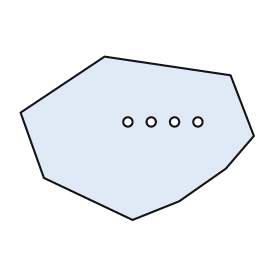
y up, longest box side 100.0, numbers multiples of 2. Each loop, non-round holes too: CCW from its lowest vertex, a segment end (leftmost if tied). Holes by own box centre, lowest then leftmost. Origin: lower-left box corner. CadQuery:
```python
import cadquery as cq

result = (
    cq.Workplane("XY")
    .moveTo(48.0, 0.0)
    .lineTo(68.0, 8.0)
    .lineTo(88.0, 22.0)
    .lineTo(100.0, 36.0)
    .lineTo(90.0, 62.0)
    .lineTo(36.0, 70.0)
    .lineTo(0.0, 46.0)
    .lineTo(10.0, 18.0)
    .close()
    .moveTo(46.0, 42.0)
    .circle(2.0)
    .moveTo(56.0, 42.0)
    .circle(2.0)
    .moveTo(66.0, 42.0)
    .circle(2.0)
    .moveTo(76.0, 42.0)
    .circle(2.0)
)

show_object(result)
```